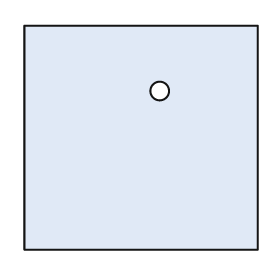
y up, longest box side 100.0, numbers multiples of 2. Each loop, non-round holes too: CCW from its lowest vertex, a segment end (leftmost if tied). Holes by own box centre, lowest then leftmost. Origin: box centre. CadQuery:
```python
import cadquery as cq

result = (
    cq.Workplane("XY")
    .moveTo(-50.0, -48.0)
    .lineTo(50.0, -48.0)
    .lineTo(50.0, 48.0)
    .lineTo(-50.0, 48.0)
    .close()
    .moveTo(8.0, 20.0)
    .circle(4.0)
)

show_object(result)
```